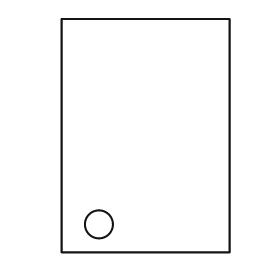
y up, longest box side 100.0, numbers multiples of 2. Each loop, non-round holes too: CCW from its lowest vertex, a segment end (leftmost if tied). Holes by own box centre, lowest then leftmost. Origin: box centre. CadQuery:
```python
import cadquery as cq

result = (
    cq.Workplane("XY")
    .moveTo(-36.0, -50.0)
    .lineTo(36.0, -50.0)
    .lineTo(36.0, 50.0)
    .lineTo(-36.0, 50.0)
    .close()
    .moveTo(-20.0, -38.0)
    .circle(6.0)
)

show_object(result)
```